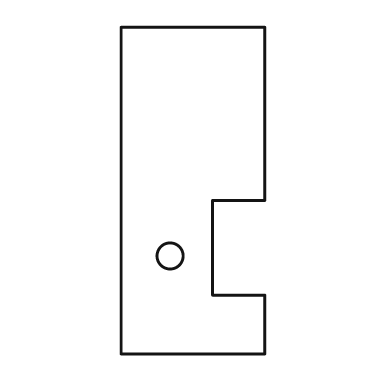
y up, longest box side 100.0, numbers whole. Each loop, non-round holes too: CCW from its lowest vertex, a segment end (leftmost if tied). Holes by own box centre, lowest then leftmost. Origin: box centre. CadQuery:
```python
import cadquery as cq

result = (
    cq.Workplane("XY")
    .moveTo(-22.0, -50.0)
    .lineTo(22.0, -50.0)
    .lineTo(22.0, -32.0)
    .lineTo(6.0, -32.0)
    .lineTo(6.0, -3.0)
    .lineTo(22.0, -3.0)
    .lineTo(22.0, 50.0)
    .lineTo(-22.0, 50.0)
    .close()
    .moveTo(-7.0, -20.0)
    .circle(4.0)
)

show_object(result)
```